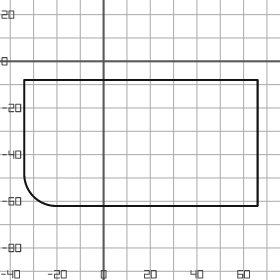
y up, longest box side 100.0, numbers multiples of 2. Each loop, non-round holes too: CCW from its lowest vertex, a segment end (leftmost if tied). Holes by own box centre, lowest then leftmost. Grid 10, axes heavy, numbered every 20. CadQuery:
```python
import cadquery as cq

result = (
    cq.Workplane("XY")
    .moveTo(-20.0, -62.0)
    .lineTo(66.0, -62.0)
    .lineTo(66.0, -8.0)
    .lineTo(-34.0, -8.0)
    .lineTo(-34.0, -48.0)
    .threePointArc((-30.0, -58.0), (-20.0, -62.0))
    .close()
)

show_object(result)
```